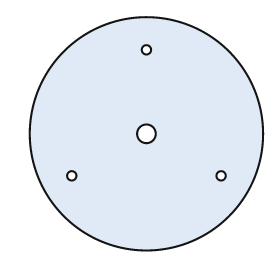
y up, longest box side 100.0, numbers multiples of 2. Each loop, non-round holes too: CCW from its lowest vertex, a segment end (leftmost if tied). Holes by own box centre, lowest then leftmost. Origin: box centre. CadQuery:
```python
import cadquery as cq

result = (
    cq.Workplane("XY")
    .moveTo(0.0, 0.0)
    .circle(50.0)
    .moveTo(-32.0, -18.0)
    .circle(2.0)
    .moveTo(32.0, -18.0)
    .circle(2.0)
    .moveTo(0.0, 0.0)
    .circle(4.0)
    .moveTo(0.0, 36.0)
    .circle(2.0)
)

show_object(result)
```